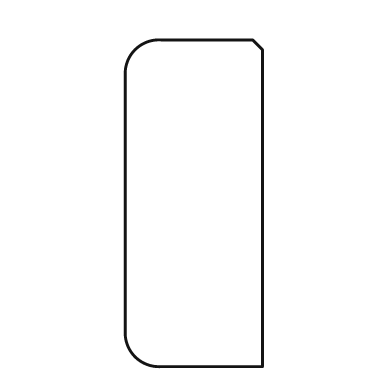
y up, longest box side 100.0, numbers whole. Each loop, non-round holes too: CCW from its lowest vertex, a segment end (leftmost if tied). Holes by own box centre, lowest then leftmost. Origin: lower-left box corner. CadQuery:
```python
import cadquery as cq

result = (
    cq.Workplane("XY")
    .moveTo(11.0, 0.0)
    .lineTo(42.0, 0.0)
    .lineTo(42.0, 97.0)
    .lineTo(39.0, 100.0)
    .lineTo(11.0, 100.0)
    .threePointArc((3.0, 97.0), (0.0, 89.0))
    .lineTo(0.0, 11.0)
    .threePointArc((3.0, 3.0), (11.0, 0.0))
    .close()
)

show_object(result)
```